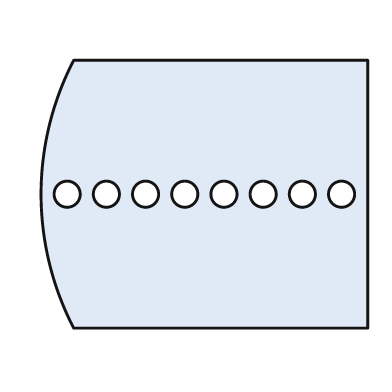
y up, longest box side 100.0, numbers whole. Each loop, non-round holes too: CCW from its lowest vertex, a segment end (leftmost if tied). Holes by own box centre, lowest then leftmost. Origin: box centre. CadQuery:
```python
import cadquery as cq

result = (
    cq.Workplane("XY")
    .moveTo(-40.0, -41.0)
    .lineTo(50.0, -41.0)
    .lineTo(50.0, 41.0)
    .lineTo(-40.0, 41.0)
    .threePointArc((-50.0, 0.0), (-40.0, -41.0))
    .close()
    .moveTo(-42.0, 0.0)
    .circle(4.0)
    .moveTo(-30.0, 0.0)
    .circle(4.0)
    .moveTo(-18.0, 0.0)
    .circle(4.0)
    .moveTo(-6.0, 0.0)
    .circle(4.0)
    .moveTo(6.0, 0.0)
    .circle(4.0)
    .moveTo(18.0, 0.0)
    .circle(4.0)
    .moveTo(30.0, 0.0)
    .circle(4.0)
    .moveTo(42.0, 0.0)
    .circle(4.0)
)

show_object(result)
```